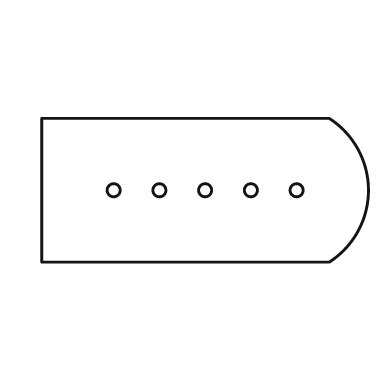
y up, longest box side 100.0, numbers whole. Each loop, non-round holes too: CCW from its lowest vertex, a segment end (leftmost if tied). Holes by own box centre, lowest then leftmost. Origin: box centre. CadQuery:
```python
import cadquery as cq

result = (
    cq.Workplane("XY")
    .moveTo(-50.0, -22.0)
    .lineTo(38.0, -22.0)
    .threePointArc((50.0, 0.0), (38.0, 22.0))
    .lineTo(-50.0, 22.0)
    .close()
    .moveTo(-28.0, 0.0)
    .circle(2.0)
    .moveTo(-14.0, 0.0)
    .circle(2.0)
    .moveTo(0.0, 0.0)
    .circle(2.0)
    .moveTo(14.0, 0.0)
    .circle(2.0)
    .moveTo(28.0, 0.0)
    .circle(2.0)
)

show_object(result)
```